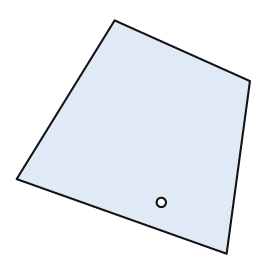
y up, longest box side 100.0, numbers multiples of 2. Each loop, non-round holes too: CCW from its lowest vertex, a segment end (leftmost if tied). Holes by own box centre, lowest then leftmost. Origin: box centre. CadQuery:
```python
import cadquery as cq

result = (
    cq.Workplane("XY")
    .moveTo(40.0, -50.0)
    .lineTo(50.0, 24.0)
    .lineTo(-8.0, 50.0)
    .lineTo(-50.0, -18.0)
    .close()
    .moveTo(12.0, -28.0)
    .circle(2.0)
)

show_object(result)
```